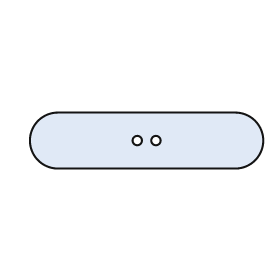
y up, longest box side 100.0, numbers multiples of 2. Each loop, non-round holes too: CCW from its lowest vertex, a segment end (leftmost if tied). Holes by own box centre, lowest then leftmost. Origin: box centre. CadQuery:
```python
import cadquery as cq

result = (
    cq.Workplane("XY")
    .moveTo(-38.0, -12.0)
    .lineTo(38.0, -12.0)
    .threePointArc((50.0, 0.0), (38.0, 12.0))
    .lineTo(-38.0, 12.0)
    .threePointArc((-50.0, 0.0), (-38.0, -12.0))
    .close()
    .moveTo(-4.0, 0.0)
    .circle(2.0)
    .moveTo(4.0, 0.0)
    .circle(2.0)
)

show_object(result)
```